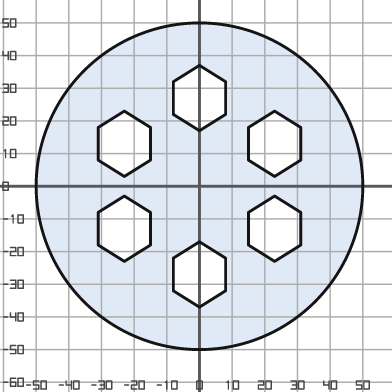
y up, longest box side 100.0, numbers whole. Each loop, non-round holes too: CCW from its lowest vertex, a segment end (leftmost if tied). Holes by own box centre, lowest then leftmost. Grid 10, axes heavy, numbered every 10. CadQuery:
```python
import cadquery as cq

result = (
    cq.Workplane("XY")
    .moveTo(0.0, 0.0)
    .circle(50.0)
    .moveTo(0.0, -37.0)
    .lineTo(8.0, -32.0)
    .lineTo(8.0, -22.0)
    .lineTo(0.0, -17.0)
    .lineTo(-8.0, -22.0)
    .lineTo(-8.0, -32.0)
    .close()
    .moveTo(-23.0, -23.0)
    .lineTo(-15.0, -18.0)
    .lineTo(-15.0, -8.0)
    .lineTo(-23.0, -3.0)
    .lineTo(-31.0, -8.0)
    .lineTo(-31.0, -18.0)
    .close()
    .moveTo(23.0, -23.0)
    .lineTo(31.0, -18.0)
    .lineTo(31.0, -8.0)
    .lineTo(23.0, -3.0)
    .lineTo(15.0, -8.0)
    .lineTo(15.0, -18.0)
    .close()
    .moveTo(-23.0, 3.0)
    .lineTo(-15.0, 8.0)
    .lineTo(-15.0, 18.0)
    .lineTo(-23.0, 23.0)
    .lineTo(-31.0, 18.0)
    .lineTo(-31.0, 8.0)
    .close()
    .moveTo(23.0, 3.0)
    .lineTo(31.0, 8.0)
    .lineTo(31.0, 18.0)
    .lineTo(23.0, 23.0)
    .lineTo(15.0, 18.0)
    .lineTo(15.0, 8.0)
    .close()
    .moveTo(0.0, 17.0)
    .lineTo(8.0, 22.0)
    .lineTo(8.0, 32.0)
    .lineTo(0.0, 37.0)
    .lineTo(-8.0, 32.0)
    .lineTo(-8.0, 22.0)
    .close()
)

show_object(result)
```